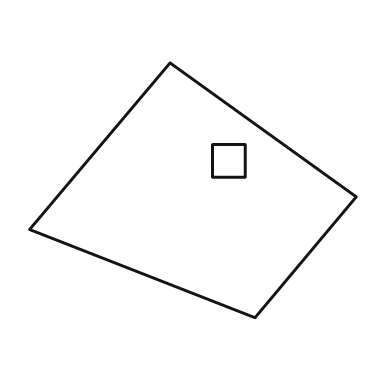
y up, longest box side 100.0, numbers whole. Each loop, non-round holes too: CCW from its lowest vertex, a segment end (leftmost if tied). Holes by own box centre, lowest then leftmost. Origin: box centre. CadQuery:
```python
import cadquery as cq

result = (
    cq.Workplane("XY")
    .moveTo(19.0, -39.0)
    .lineTo(50.0, -2.0)
    .lineTo(-7.0, 39.0)
    .lineTo(-50.0, -12.0)
    .close()
    .moveTo(6.0, 4.0)
    .lineTo(16.0, 4.0)
    .lineTo(16.0, 14.0)
    .lineTo(6.0, 14.0)
    .close()
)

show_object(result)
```